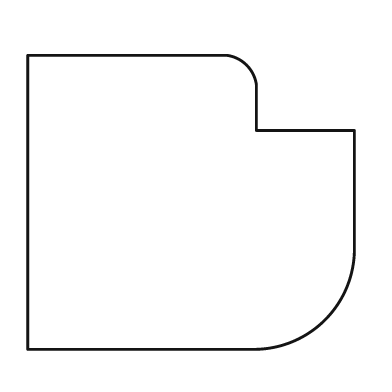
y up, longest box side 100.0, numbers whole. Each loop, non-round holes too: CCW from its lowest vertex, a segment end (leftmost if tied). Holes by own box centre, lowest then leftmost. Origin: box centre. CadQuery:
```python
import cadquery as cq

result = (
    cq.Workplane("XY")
    .moveTo(-50.0, -45.0)
    .lineTo(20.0, -45.0)
    .threePointArc((41.0, -36.0), (50.0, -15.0))
    .lineTo(50.0, 22.0)
    .lineTo(20.0, 22.0)
    .lineTo(20.0, 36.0)
    .threePointArc((17.0, 42.0), (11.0, 45.0))
    .lineTo(-50.0, 45.0)
    .close()
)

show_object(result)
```